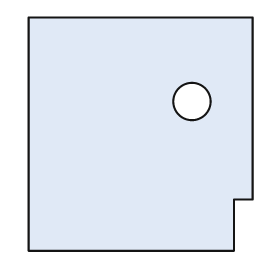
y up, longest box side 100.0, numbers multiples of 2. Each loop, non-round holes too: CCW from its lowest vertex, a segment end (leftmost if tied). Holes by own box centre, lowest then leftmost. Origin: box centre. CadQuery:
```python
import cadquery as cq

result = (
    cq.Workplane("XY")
    .moveTo(-48.0, -50.0)
    .lineTo(40.0, -50.0)
    .lineTo(40.0, -28.0)
    .lineTo(48.0, -28.0)
    .lineTo(48.0, 50.0)
    .lineTo(-48.0, 50.0)
    .close()
    .moveTo(22.0, 14.0)
    .circle(8.0)
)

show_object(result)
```